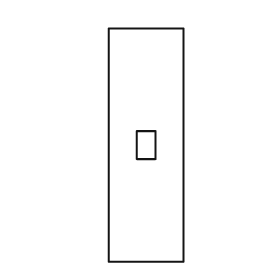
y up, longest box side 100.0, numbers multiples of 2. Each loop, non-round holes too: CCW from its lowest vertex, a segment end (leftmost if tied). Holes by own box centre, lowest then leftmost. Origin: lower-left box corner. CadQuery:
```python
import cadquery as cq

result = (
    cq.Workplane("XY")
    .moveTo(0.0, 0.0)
    .lineTo(32.0, 0.0)
    .lineTo(32.0, 100.0)
    .lineTo(0.0, 100.0)
    .close()
    .moveTo(12.0, 44.0)
    .lineTo(20.0, 44.0)
    .lineTo(20.0, 56.0)
    .lineTo(12.0, 56.0)
    .close()
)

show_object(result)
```